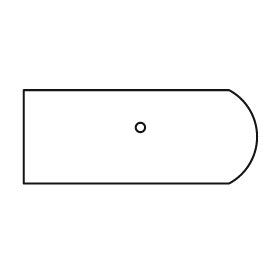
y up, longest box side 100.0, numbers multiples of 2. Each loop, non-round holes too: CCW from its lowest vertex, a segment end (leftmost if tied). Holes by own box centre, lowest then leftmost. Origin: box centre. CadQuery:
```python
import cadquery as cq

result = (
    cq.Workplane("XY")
    .moveTo(-50.0, -20.0)
    .lineTo(38.0, -20.0)
    .threePointArc((50.0, 0.0), (38.0, 20.0))
    .lineTo(-50.0, 20.0)
    .close()
    .moveTo(0.0, 4.0)
    .circle(2.0)
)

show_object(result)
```